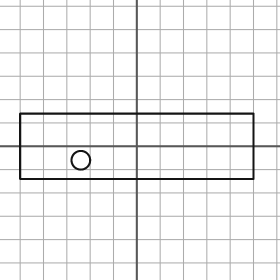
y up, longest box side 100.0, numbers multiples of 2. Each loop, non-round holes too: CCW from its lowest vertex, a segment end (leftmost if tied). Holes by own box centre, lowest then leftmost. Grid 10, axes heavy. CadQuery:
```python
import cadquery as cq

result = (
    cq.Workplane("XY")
    .moveTo(-50.0, -14.0)
    .lineTo(50.0, -14.0)
    .lineTo(50.0, 14.0)
    .lineTo(-50.0, 14.0)
    .close()
    .moveTo(-24.0, -6.0)
    .circle(4.0)
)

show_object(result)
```